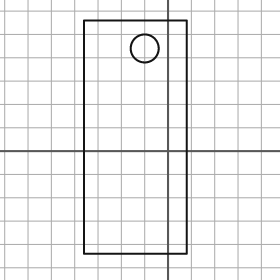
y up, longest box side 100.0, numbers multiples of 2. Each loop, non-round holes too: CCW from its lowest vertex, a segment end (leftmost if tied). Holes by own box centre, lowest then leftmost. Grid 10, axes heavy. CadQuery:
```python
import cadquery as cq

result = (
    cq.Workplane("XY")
    .moveTo(-36.0, -44.0)
    .lineTo(8.0, -44.0)
    .lineTo(8.0, 56.0)
    .lineTo(-36.0, 56.0)
    .close()
    .moveTo(-10.0, 44.0)
    .circle(6.0)
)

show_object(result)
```